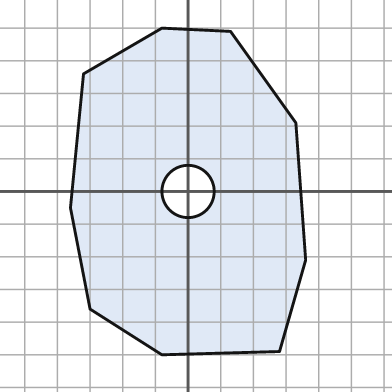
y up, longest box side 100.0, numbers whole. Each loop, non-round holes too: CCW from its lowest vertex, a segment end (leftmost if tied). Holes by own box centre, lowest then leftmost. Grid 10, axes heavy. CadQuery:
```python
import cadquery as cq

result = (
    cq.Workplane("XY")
    .moveTo(-8.0, -50.0)
    .lineTo(28.0, -49.0)
    .lineTo(36.0, -21.0)
    .lineTo(33.0, 21.0)
    .lineTo(13.0, 49.0)
    .lineTo(-8.0, 50.0)
    .lineTo(-32.0, 36.0)
    .lineTo(-36.0, -5.0)
    .lineTo(-30.0, -36.0)
    .close()
    .moveTo(0.0, 0.0)
    .circle(8.0)
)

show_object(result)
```